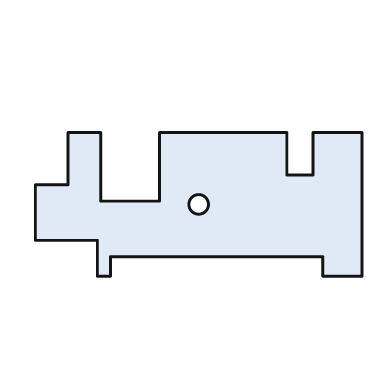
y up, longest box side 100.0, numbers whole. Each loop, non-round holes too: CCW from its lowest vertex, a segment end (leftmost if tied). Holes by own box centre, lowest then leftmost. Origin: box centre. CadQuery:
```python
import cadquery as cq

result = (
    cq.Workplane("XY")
    .moveTo(-31.0, -22.0)
    .lineTo(-27.0, -22.0)
    .lineTo(-27.0, -16.0)
    .lineTo(38.0, -16.0)
    .lineTo(38.0, -22.0)
    .lineTo(50.0, -22.0)
    .lineTo(50.0, 22.0)
    .lineTo(35.0, 22.0)
    .lineTo(35.0, 9.0)
    .lineTo(27.0, 9.0)
    .lineTo(27.0, 22.0)
    .lineTo(-12.0, 22.0)
    .lineTo(-12.0, 1.0)
    .lineTo(-30.0, 1.0)
    .lineTo(-30.0, 22.0)
    .lineTo(-40.0, 22.0)
    .lineTo(-40.0, 6.0)
    .lineTo(-50.0, 6.0)
    .lineTo(-50.0, -11.0)
    .lineTo(-31.0, -11.0)
    .close()
    .moveTo(0.0, 0.0)
    .circle(3.0)
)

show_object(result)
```